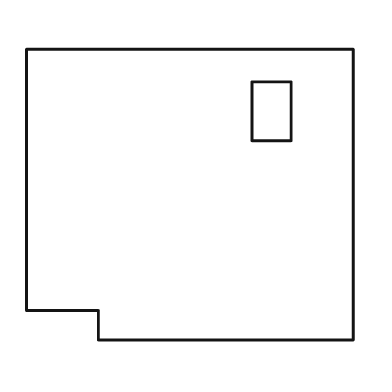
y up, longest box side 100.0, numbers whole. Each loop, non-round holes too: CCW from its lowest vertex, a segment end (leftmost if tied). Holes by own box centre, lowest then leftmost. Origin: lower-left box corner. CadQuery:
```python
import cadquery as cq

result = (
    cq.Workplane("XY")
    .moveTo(22.0, 0.0)
    .lineTo(100.0, 0.0)
    .lineTo(100.0, 89.0)
    .lineTo(0.0, 89.0)
    .lineTo(0.0, 9.0)
    .lineTo(22.0, 9.0)
    .close()
    .moveTo(69.0, 61.0)
    .lineTo(81.0, 61.0)
    .lineTo(81.0, 79.0)
    .lineTo(69.0, 79.0)
    .close()
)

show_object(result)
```